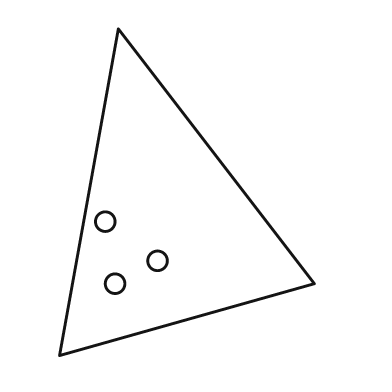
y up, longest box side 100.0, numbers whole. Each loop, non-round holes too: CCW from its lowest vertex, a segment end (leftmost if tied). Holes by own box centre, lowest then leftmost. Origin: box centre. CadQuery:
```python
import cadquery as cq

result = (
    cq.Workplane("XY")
    .moveTo(-39.0, -50.0)
    .lineTo(39.0, -28.0)
    .lineTo(-21.0, 50.0)
    .close()
    .moveTo(-22.0, -28.0)
    .circle(3.0)
    .moveTo(-9.0, -21.0)
    .circle(3.0)
    .moveTo(-25.0, -9.0)
    .circle(3.0)
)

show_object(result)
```